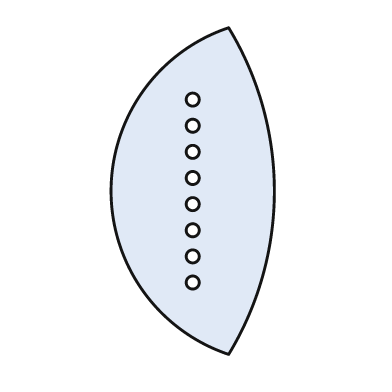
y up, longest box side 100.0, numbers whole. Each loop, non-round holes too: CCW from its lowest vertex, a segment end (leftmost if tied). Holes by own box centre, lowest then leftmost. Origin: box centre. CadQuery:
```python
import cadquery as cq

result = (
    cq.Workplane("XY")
    .moveTo(11.0, -50.0)
    .threePointArc((25.0, 0.0), (11.0, 50.0))
    .threePointArc((-25.0, 0.0), (11.0, -50.0))
    .close()
    .moveTo(0.0, -28.0)
    .circle(2.0)
    .moveTo(0.0, -20.0)
    .circle(2.0)
    .moveTo(0.0, -12.0)
    .circle(2.0)
    .moveTo(0.0, -4.0)
    .circle(2.0)
    .moveTo(0.0, 4.0)
    .circle(2.0)
    .moveTo(0.0, 12.0)
    .circle(2.0)
    .moveTo(0.0, 20.0)
    .circle(2.0)
    .moveTo(0.0, 28.0)
    .circle(2.0)
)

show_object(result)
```